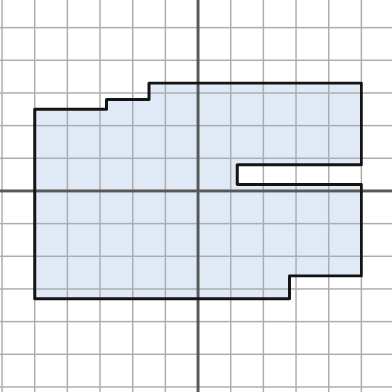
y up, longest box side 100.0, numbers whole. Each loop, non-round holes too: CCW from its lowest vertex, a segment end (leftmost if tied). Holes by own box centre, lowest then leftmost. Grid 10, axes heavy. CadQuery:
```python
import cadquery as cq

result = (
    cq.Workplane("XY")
    .moveTo(-50.0, -33.0)
    .lineTo(28.0, -33.0)
    .lineTo(28.0, -26.0)
    .lineTo(50.0, -26.0)
    .lineTo(50.0, 2.0)
    .lineTo(12.0, 2.0)
    .lineTo(12.0, 8.0)
    .lineTo(50.0, 8.0)
    .lineTo(50.0, 33.0)
    .lineTo(-15.0, 33.0)
    .lineTo(-15.0, 28.0)
    .lineTo(-28.0, 28.0)
    .lineTo(-28.0, 25.0)
    .lineTo(-50.0, 25.0)
    .close()
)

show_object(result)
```